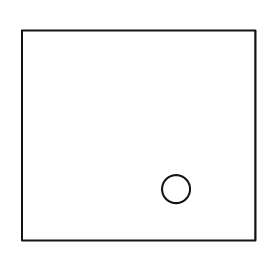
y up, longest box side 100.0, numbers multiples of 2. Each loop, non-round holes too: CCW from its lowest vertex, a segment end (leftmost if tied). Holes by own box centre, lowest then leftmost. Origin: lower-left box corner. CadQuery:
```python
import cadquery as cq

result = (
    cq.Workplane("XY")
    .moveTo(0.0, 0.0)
    .lineTo(100.0, 0.0)
    .lineTo(100.0, 90.0)
    .lineTo(0.0, 90.0)
    .close()
    .moveTo(66.0, 22.0)
    .circle(6.0)
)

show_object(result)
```